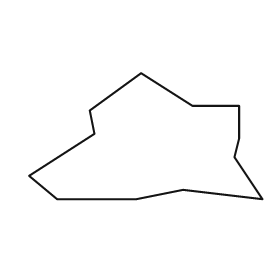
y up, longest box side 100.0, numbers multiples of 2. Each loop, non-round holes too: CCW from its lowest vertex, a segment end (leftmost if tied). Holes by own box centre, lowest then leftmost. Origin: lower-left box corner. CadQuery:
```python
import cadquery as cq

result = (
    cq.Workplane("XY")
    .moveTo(12.0, 0.0)
    .lineTo(46.0, 0.0)
    .lineTo(66.0, 4.0)
    .lineTo(100.0, 0.0)
    .lineTo(88.0, 18.0)
    .lineTo(90.0, 26.0)
    .lineTo(90.0, 40.0)
    .lineTo(70.0, 40.0)
    .lineTo(48.0, 54.0)
    .lineTo(26.0, 38.0)
    .lineTo(28.0, 28.0)
    .lineTo(0.0, 10.0)
    .close()
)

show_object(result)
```